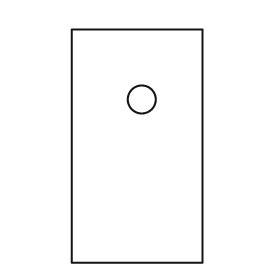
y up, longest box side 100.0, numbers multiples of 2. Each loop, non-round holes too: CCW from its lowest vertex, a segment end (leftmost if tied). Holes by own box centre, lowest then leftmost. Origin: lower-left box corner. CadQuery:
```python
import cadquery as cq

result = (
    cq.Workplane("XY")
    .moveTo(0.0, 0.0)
    .lineTo(56.0, 0.0)
    .lineTo(56.0, 100.0)
    .lineTo(0.0, 100.0)
    .close()
    .moveTo(30.0, 70.0)
    .circle(6.0)
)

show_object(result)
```